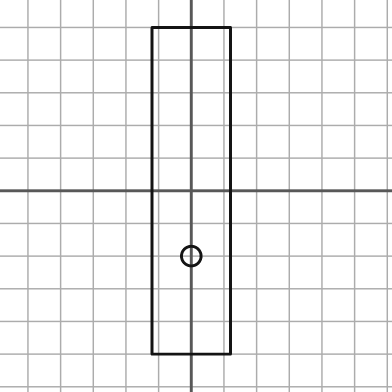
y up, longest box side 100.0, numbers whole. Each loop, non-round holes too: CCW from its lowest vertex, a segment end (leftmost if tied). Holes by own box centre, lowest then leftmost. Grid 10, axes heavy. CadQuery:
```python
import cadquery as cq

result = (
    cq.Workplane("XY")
    .moveTo(-12.0, -50.0)
    .lineTo(12.0, -50.0)
    .lineTo(12.0, 50.0)
    .lineTo(-12.0, 50.0)
    .close()
    .moveTo(0.0, -20.0)
    .circle(3.0)
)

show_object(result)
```